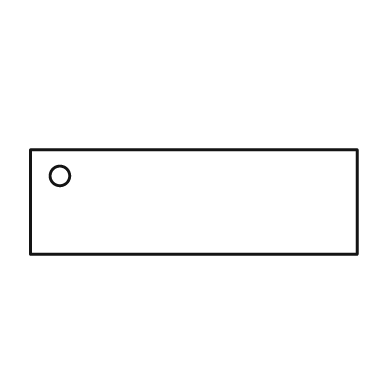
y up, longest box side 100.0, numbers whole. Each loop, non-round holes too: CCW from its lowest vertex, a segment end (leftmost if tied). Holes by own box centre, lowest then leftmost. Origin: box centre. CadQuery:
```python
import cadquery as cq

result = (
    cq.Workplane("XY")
    .moveTo(-50.0, -16.0)
    .lineTo(50.0, -16.0)
    .lineTo(50.0, 16.0)
    .lineTo(-50.0, 16.0)
    .close()
    .moveTo(-41.0, 8.0)
    .circle(3.0)
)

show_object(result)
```